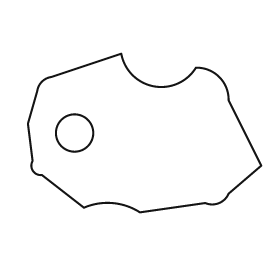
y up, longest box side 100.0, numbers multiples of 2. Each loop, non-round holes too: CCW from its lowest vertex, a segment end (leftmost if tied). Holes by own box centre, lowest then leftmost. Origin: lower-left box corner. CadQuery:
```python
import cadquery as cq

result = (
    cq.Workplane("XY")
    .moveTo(48.0, 0.0)
    .lineTo(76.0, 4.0)
    .threePointArc((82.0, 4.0), (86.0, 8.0))
    .lineTo(100.0, 20.0)
    .lineTo(86.0, 48.0)
    .threePointArc((82.0, 58.0), (72.0, 62.0))
    .threePointArc((54.0, 54.0), (40.0, 68.0))
    .lineTo(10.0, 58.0)
    .threePointArc((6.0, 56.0), (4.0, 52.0))
    .lineTo(0.0, 38.0)
    .lineTo(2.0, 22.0)
    .threePointArc((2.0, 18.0), (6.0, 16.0))
    .lineTo(24.0, 2.0)
    .threePointArc((36.0, 4.0), (48.0, 0.0))
    .close()
    .moveTo(20.0, 34.0)
    .circle(8.0)
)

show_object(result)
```